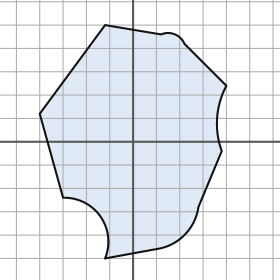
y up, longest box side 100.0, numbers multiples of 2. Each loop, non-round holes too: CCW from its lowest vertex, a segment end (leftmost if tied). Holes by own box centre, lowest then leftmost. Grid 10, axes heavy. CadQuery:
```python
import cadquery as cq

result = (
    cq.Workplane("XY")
    .moveTo(-12.0, -50.0)
    .lineTo(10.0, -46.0)
    .threePointArc((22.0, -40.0), (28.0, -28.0))
    .lineTo(38.0, -4.0)
    .threePointArc((36.0, 10.0), (40.0, 24.0))
    .lineTo(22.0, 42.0)
    .threePointArc((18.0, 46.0), (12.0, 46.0))
    .lineTo(-12.0, 50.0)
    .lineTo(-40.0, 12.0)
    .lineTo(-30.0, -24.0)
    .threePointArc((-14.0, -32.0), (-12.0, -50.0))
    .close()
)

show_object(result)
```